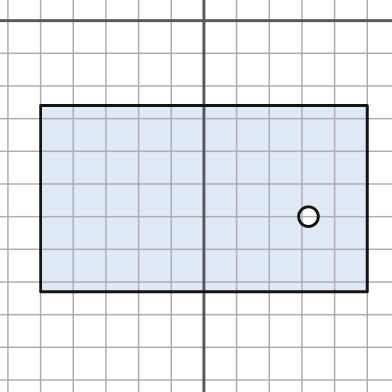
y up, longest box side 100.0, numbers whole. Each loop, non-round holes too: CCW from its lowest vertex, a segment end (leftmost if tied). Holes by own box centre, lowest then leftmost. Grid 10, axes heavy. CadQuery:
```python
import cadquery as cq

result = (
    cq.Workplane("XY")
    .moveTo(-50.0, -83.0)
    .lineTo(50.0, -83.0)
    .lineTo(50.0, -26.0)
    .lineTo(-50.0, -26.0)
    .close()
    .moveTo(32.0, -60.0)
    .circle(3.0)
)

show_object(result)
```